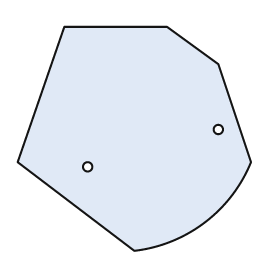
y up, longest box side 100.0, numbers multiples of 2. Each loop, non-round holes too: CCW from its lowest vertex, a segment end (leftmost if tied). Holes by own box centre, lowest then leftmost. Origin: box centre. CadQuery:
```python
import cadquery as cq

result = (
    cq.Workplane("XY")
    .moveTo(0.0, -48.0)
    .threePointArc((30.0, -36.0), (50.0, -10.0))
    .lineTo(36.0, 32.0)
    .lineTo(14.0, 48.0)
    .lineTo(-30.0, 48.0)
    .lineTo(-50.0, -10.0)
    .close()
    .moveTo(-20.0, -12.0)
    .circle(2.0)
    .moveTo(36.0, 4.0)
    .circle(2.0)
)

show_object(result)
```